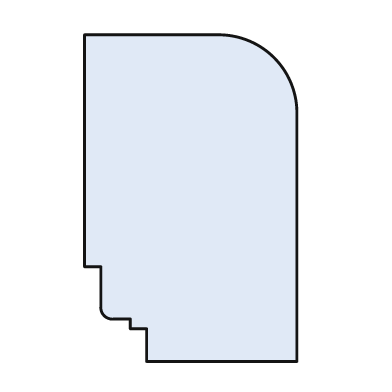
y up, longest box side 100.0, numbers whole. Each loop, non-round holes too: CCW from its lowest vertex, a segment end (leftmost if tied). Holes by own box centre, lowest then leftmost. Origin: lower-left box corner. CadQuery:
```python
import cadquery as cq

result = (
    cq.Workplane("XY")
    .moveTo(19.0, 0.0)
    .lineTo(65.0, 0.0)
    .lineTo(65.0, 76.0)
    .threePointArc((58.0, 93.0), (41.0, 100.0))
    .lineTo(0.0, 100.0)
    .lineTo(0.0, 29.0)
    .lineTo(5.0, 29.0)
    .lineTo(5.0, 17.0)
    .threePointArc((6.0, 14.0), (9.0, 13.0))
    .lineTo(14.0, 13.0)
    .lineTo(14.0, 10.0)
    .lineTo(19.0, 10.0)
    .close()
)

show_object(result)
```